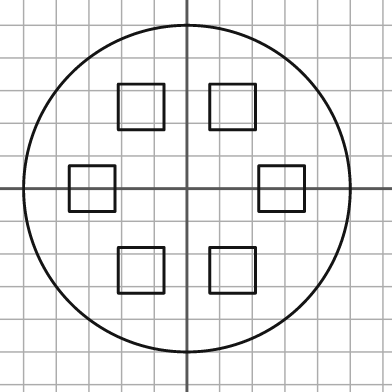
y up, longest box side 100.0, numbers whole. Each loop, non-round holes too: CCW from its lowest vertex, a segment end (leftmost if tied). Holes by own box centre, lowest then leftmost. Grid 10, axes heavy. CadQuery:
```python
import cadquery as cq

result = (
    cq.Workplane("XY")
    .moveTo(0.0, 0.0)
    .circle(50.0)
    .moveTo(-21.0, -32.0)
    .lineTo(-7.0, -32.0)
    .lineTo(-7.0, -18.0)
    .lineTo(-21.0, -18.0)
    .close()
    .moveTo(7.0, -32.0)
    .lineTo(21.0, -32.0)
    .lineTo(21.0, -18.0)
    .lineTo(7.0, -18.0)
    .close()
    .moveTo(-36.0, -7.0)
    .lineTo(-22.0, -7.0)
    .lineTo(-22.0, 7.0)
    .lineTo(-36.0, 7.0)
    .close()
    .moveTo(22.0, -7.0)
    .lineTo(36.0, -7.0)
    .lineTo(36.0, 7.0)
    .lineTo(22.0, 7.0)
    .close()
    .moveTo(-21.0, 18.0)
    .lineTo(-7.0, 18.0)
    .lineTo(-7.0, 32.0)
    .lineTo(-21.0, 32.0)
    .close()
    .moveTo(7.0, 18.0)
    .lineTo(21.0, 18.0)
    .lineTo(21.0, 32.0)
    .lineTo(7.0, 32.0)
    .close()
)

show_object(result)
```